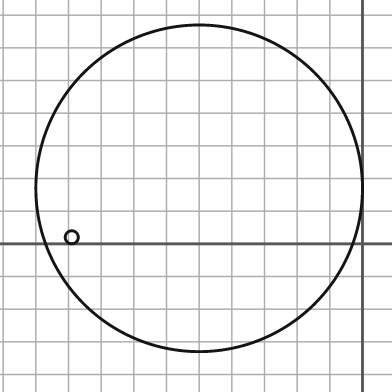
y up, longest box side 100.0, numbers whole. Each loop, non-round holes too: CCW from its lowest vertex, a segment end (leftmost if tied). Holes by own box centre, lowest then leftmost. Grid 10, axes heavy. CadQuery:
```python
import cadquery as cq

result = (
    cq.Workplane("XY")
    .moveTo(-50.0, 17.0)
    .circle(50.0)
    .moveTo(-89.0, 2.0)
    .circle(2.0)
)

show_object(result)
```